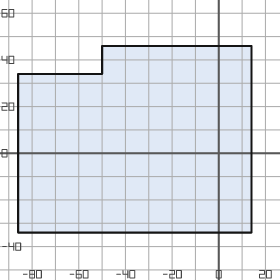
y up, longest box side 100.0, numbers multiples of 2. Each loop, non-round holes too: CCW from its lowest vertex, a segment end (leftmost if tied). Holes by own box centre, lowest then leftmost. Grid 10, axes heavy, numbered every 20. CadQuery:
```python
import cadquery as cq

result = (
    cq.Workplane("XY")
    .moveTo(-86.0, -34.0)
    .lineTo(14.0, -34.0)
    .lineTo(14.0, 46.0)
    .lineTo(-50.0, 46.0)
    .lineTo(-50.0, 34.0)
    .lineTo(-86.0, 34.0)
    .close()
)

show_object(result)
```